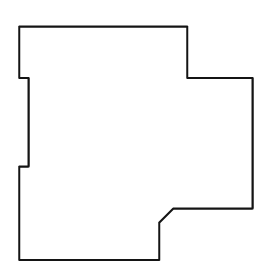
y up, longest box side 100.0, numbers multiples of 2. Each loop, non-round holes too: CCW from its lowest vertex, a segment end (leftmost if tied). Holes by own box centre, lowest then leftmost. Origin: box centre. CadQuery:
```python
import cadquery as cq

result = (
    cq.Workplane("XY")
    .moveTo(-50.0, -50.0)
    .lineTo(10.0, -50.0)
    .lineTo(10.0, -34.0)
    .lineTo(16.0, -28.0)
    .lineTo(50.0, -28.0)
    .lineTo(50.0, 28.0)
    .lineTo(22.0, 28.0)
    .lineTo(22.0, 50.0)
    .lineTo(-50.0, 50.0)
    .lineTo(-50.0, 28.0)
    .lineTo(-46.0, 28.0)
    .lineTo(-46.0, -10.0)
    .lineTo(-50.0, -10.0)
    .close()
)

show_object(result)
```